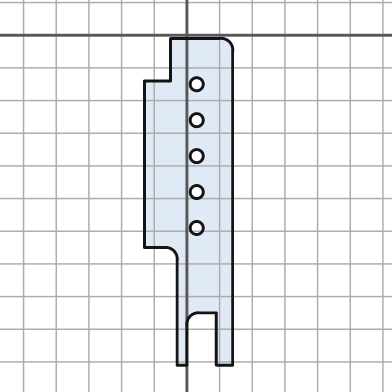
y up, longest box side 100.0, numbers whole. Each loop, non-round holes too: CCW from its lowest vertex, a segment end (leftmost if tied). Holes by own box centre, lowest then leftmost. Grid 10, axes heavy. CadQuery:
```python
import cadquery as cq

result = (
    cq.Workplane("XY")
    .moveTo(-3.0, -101.0)
    .lineTo(0.0, -101.0)
    .lineTo(0.0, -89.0)
    .threePointArc((1.0, -86.0), (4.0, -85.0))
    .lineTo(9.0, -85.0)
    .lineTo(9.0, -101.0)
    .lineTo(14.0, -101.0)
    .lineTo(14.0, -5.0)
    .threePointArc((13.0, -2.0), (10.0, -1.0))
    .lineTo(-5.0, -1.0)
    .lineTo(-5.0, -14.0)
    .lineTo(-13.0, -14.0)
    .lineTo(-13.0, -65.0)
    .lineTo(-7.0, -65.0)
    .threePointArc((-4.0, -66.0), (-3.0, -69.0))
    .close()
    .moveTo(3.0, -59.0)
    .circle(2.0)
    .moveTo(3.0, -48.0)
    .circle(2.0)
    .moveTo(3.0, -37.0)
    .circle(2.0)
    .moveTo(3.0, -26.0)
    .circle(2.0)
    .moveTo(3.0, -15.0)
    .circle(2.0)
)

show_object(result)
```